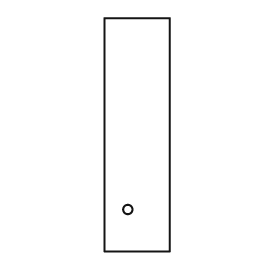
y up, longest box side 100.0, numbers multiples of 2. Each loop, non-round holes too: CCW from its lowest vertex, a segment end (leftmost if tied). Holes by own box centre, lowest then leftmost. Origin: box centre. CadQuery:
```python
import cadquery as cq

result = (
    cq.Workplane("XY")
    .moveTo(-14.0, -50.0)
    .lineTo(14.0, -50.0)
    .lineTo(14.0, 50.0)
    .lineTo(-14.0, 50.0)
    .close()
    .moveTo(-4.0, -32.0)
    .circle(2.0)
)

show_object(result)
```